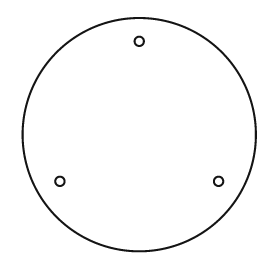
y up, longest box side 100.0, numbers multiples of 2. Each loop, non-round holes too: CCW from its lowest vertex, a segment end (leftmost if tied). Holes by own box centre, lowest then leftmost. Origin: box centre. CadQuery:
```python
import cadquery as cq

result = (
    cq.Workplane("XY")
    .moveTo(0.0, 0.0)
    .circle(50.0)
    .moveTo(-34.0, -20.0)
    .circle(2.0)
    .moveTo(34.0, -20.0)
    .circle(2.0)
    .moveTo(0.0, 40.0)
    .circle(2.0)
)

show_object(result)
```